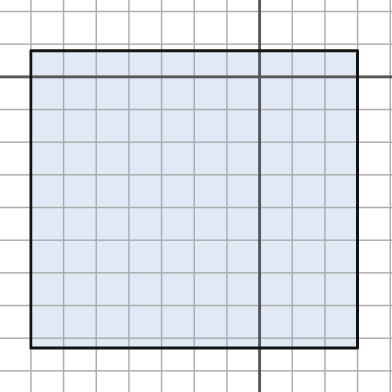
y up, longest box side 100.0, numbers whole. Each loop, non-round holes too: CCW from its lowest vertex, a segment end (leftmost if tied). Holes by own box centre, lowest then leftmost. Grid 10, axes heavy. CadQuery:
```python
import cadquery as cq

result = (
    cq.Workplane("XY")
    .moveTo(-70.0, -83.0)
    .lineTo(30.0, -83.0)
    .lineTo(30.0, 8.0)
    .lineTo(-70.0, 8.0)
    .close()
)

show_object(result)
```